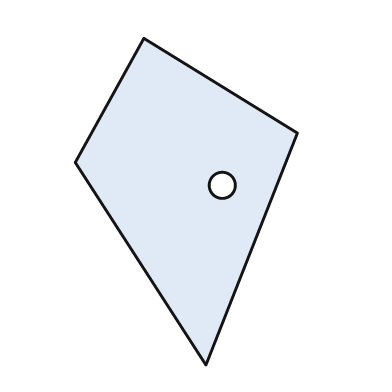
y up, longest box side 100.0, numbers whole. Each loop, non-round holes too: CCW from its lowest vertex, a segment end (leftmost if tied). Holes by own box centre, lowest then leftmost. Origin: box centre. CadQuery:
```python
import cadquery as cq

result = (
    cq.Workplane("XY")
    .moveTo(6.0, -50.0)
    .lineTo(34.0, 21.0)
    .lineTo(-13.0, 50.0)
    .lineTo(-34.0, 12.0)
    .close()
    .moveTo(11.0, 5.0)
    .circle(4.0)
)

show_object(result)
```